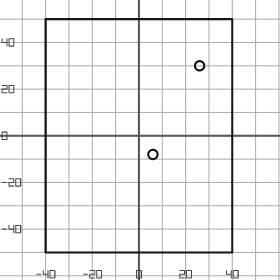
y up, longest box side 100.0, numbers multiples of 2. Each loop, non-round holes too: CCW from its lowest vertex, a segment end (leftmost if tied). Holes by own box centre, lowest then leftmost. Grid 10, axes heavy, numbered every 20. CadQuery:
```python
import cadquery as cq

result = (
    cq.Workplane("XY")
    .moveTo(-40.0, -50.0)
    .lineTo(40.0, -50.0)
    .lineTo(40.0, 50.0)
    .lineTo(-40.0, 50.0)
    .close()
    .moveTo(6.0, -8.0)
    .circle(2.0)
    .moveTo(26.0, 30.0)
    .circle(2.0)
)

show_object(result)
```